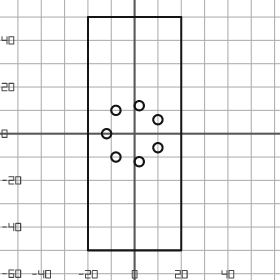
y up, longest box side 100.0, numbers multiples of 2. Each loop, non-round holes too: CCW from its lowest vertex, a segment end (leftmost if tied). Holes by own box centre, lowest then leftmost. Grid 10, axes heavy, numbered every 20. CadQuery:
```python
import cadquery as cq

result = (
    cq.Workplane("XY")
    .moveTo(-20.0, -50.0)
    .lineTo(20.0, -50.0)
    .lineTo(20.0, 50.0)
    .lineTo(-20.0, 50.0)
    .close()
    .moveTo(2.0, -12.0)
    .circle(2.0)
    .moveTo(-8.0, -10.0)
    .circle(2.0)
    .moveTo(10.0, -6.0)
    .circle(2.0)
    .moveTo(-12.0, 0.0)
    .circle(2.0)
    .moveTo(10.0, 6.0)
    .circle(2.0)
    .moveTo(-8.0, 10.0)
    .circle(2.0)
    .moveTo(2.0, 12.0)
    .circle(2.0)
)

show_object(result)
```